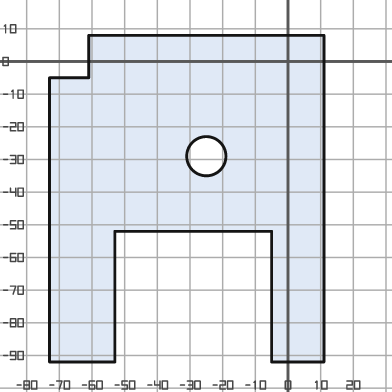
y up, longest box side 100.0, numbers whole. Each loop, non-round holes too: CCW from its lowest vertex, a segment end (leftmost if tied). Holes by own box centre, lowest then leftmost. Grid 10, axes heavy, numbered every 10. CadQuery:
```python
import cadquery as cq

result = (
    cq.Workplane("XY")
    .moveTo(-73.0, -92.0)
    .lineTo(-53.0, -92.0)
    .lineTo(-53.0, -52.0)
    .lineTo(-5.0, -52.0)
    .lineTo(-5.0, -92.0)
    .lineTo(11.0, -92.0)
    .lineTo(11.0, 8.0)
    .lineTo(-61.0, 8.0)
    .lineTo(-61.0, -5.0)
    .lineTo(-73.0, -5.0)
    .close()
    .moveTo(-25.0, -29.0)
    .circle(6.0)
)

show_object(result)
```